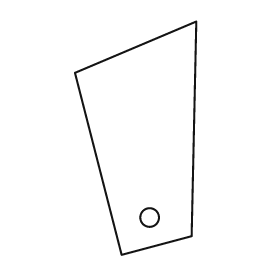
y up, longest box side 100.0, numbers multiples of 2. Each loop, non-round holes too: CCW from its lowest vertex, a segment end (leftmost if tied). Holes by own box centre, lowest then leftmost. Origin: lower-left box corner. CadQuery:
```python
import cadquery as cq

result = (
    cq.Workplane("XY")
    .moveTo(20.0, 0.0)
    .lineTo(50.0, 8.0)
    .lineTo(52.0, 100.0)
    .lineTo(0.0, 78.0)
    .close()
    .moveTo(32.0, 16.0)
    .circle(4.0)
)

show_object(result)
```